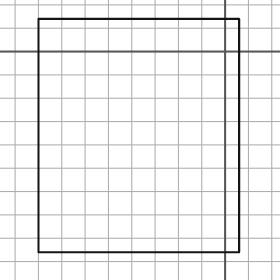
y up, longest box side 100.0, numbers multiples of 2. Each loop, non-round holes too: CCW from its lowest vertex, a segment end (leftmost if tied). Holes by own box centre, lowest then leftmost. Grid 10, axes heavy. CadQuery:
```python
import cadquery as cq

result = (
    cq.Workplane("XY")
    .moveTo(-80.0, -86.0)
    .lineTo(6.0, -86.0)
    .lineTo(6.0, 14.0)
    .lineTo(-80.0, 14.0)
    .close()
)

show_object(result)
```